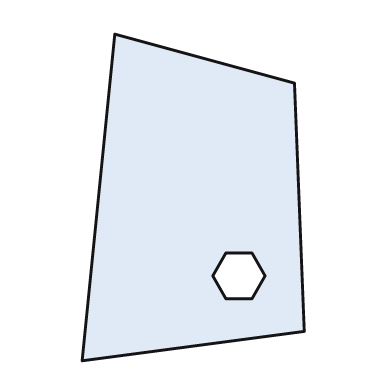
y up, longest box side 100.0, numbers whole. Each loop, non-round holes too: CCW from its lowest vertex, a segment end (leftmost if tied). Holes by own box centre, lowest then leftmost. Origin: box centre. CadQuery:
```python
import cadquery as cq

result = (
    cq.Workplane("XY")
    .moveTo(-34.0, -50.0)
    .lineTo(34.0, -41.0)
    .lineTo(31.0, 35.0)
    .lineTo(-24.0, 50.0)
    .close()
    .moveTo(10.0, -31.0)
    .lineTo(18.0, -31.0)
    .lineTo(22.0, -24.0)
    .lineTo(18.0, -17.0)
    .lineTo(10.0, -17.0)
    .lineTo(6.0, -24.0)
    .close()
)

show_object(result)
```